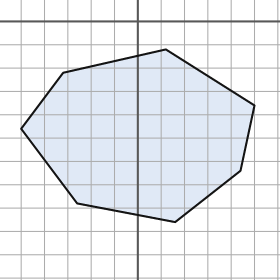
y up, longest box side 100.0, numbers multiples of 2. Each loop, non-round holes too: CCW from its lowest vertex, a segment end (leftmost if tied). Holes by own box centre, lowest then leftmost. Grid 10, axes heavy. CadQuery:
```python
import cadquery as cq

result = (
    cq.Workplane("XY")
    .moveTo(16.0, -86.0)
    .lineTo(44.0, -64.0)
    .lineTo(50.0, -36.0)
    .lineTo(12.0, -12.0)
    .lineTo(-32.0, -22.0)
    .lineTo(-50.0, -46.0)
    .lineTo(-26.0, -78.0)
    .close()
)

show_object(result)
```